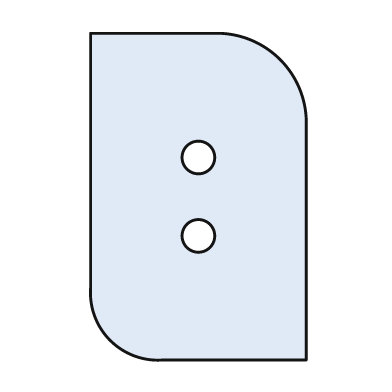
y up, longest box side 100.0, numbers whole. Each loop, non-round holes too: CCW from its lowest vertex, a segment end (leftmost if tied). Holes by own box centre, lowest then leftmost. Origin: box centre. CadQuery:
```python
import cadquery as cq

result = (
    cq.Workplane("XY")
    .moveTo(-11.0, -50.0)
    .lineTo(33.0, -50.0)
    .lineTo(33.0, 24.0)
    .threePointArc((25.0, 42.0), (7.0, 50.0))
    .lineTo(-33.0, 50.0)
    .lineTo(-33.0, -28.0)
    .threePointArc((-27.0, -44.0), (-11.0, -50.0))
    .close()
    .moveTo(0.0, -12.0)
    .circle(5.0)
    .moveTo(0.0, 12.0)
    .circle(5.0)
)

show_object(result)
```